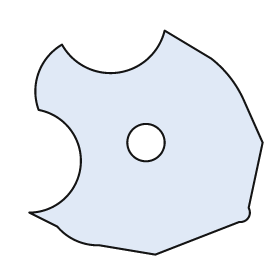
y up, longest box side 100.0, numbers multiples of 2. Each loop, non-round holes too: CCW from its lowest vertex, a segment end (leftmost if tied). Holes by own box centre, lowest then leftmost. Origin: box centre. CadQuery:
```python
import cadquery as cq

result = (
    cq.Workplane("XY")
    .moveTo(4.0, -48.0)
    .lineTo(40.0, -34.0)
    .threePointArc((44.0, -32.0), (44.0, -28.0))
    .lineTo(50.0, 0.0)
    .lineTo(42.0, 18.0)
    .threePointArc((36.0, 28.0), (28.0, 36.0))
    .lineTo(8.0, 48.0)
    .threePointArc((-12.0, 30.0), (-36.0, 42.0))
    .threePointArc((-46.0, 30.0), (-46.0, 14.0))
    .threePointArc((-28.0, -10.0), (-50.0, -30.0))
    .lineTo(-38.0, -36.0)
    .threePointArc((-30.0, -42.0), (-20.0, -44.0))
    .close()
    .moveTo(0.0, 0.0)
    .circle(8.0)
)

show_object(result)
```